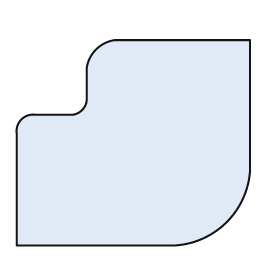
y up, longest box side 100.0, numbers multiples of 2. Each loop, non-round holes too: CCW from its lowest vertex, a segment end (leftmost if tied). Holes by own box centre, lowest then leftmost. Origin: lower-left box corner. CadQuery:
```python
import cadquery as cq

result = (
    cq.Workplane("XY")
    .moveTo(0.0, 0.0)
    .lineTo(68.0, 0.0)
    .threePointArc((90.0, 10.0), (100.0, 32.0))
    .lineTo(100.0, 88.0)
    .lineTo(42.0, 88.0)
    .threePointArc((34.0, 84.0), (30.0, 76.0))
    .lineTo(30.0, 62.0)
    .threePointArc((28.0, 58.0), (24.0, 56.0))
    .lineTo(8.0, 56.0)
    .threePointArc((2.0, 54.0), (0.0, 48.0))
    .close()
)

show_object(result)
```